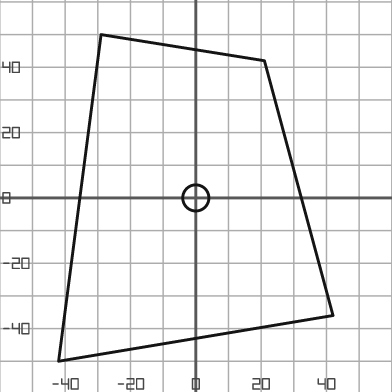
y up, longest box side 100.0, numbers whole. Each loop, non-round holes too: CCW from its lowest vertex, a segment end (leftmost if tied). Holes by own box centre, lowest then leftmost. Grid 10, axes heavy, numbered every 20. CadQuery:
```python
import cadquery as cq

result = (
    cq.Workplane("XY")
    .moveTo(-42.0, -50.0)
    .lineTo(42.0, -36.0)
    .lineTo(21.0, 42.0)
    .lineTo(-29.0, 50.0)
    .close()
    .moveTo(0.0, 0.0)
    .circle(4.0)
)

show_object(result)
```